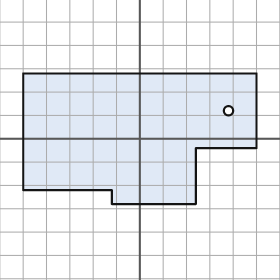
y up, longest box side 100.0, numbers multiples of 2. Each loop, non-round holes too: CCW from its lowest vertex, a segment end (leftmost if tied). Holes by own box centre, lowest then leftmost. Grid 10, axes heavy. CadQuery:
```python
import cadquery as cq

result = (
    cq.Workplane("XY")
    .moveTo(-12.0, -28.0)
    .lineTo(24.0, -28.0)
    .lineTo(24.0, -4.0)
    .lineTo(50.0, -4.0)
    .lineTo(50.0, 28.0)
    .lineTo(-50.0, 28.0)
    .lineTo(-50.0, -22.0)
    .lineTo(-12.0, -22.0)
    .close()
    .moveTo(38.0, 12.0)
    .circle(2.0)
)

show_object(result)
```